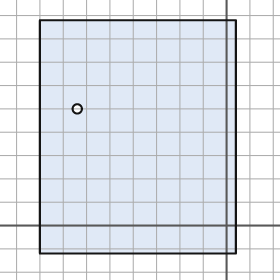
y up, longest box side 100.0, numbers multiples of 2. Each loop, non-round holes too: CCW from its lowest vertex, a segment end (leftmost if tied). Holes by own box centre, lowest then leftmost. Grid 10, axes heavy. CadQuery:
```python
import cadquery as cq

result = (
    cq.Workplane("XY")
    .moveTo(-80.0, -12.0)
    .lineTo(4.0, -12.0)
    .lineTo(4.0, 88.0)
    .lineTo(-80.0, 88.0)
    .close()
    .moveTo(-64.0, 50.0)
    .circle(2.0)
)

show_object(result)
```